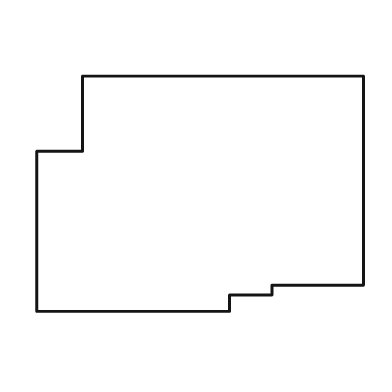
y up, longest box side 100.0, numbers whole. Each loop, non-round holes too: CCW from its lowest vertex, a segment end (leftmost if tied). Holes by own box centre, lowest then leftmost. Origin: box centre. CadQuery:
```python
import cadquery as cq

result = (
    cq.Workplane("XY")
    .moveTo(-50.0, -36.0)
    .lineTo(9.0, -36.0)
    .lineTo(9.0, -31.0)
    .lineTo(22.0, -31.0)
    .lineTo(22.0, -28.0)
    .lineTo(50.0, -28.0)
    .lineTo(50.0, 36.0)
    .lineTo(-36.0, 36.0)
    .lineTo(-36.0, 13.0)
    .lineTo(-50.0, 13.0)
    .close()
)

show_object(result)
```